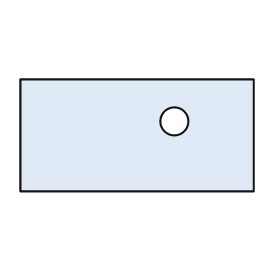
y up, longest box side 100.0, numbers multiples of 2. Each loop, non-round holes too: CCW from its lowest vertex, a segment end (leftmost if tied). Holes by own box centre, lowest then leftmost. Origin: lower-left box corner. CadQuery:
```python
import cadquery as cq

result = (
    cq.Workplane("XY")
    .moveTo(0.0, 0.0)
    .lineTo(100.0, 0.0)
    .lineTo(100.0, 48.0)
    .lineTo(0.0, 48.0)
    .close()
    .moveTo(66.0, 30.0)
    .circle(6.0)
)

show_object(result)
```